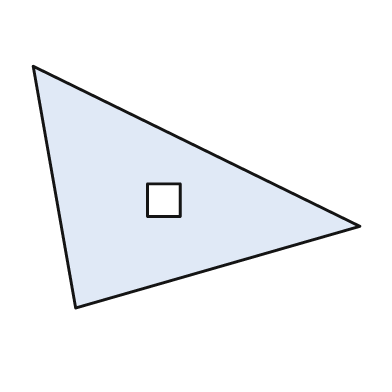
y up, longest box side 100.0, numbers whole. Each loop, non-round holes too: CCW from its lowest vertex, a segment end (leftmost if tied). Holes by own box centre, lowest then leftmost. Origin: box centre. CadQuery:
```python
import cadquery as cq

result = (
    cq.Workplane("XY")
    .moveTo(-37.0, -37.0)
    .lineTo(50.0, -12.0)
    .lineTo(-50.0, 37.0)
    .close()
    .moveTo(-15.0, -9.0)
    .lineTo(-5.0, -9.0)
    .lineTo(-5.0, 1.0)
    .lineTo(-15.0, 1.0)
    .close()
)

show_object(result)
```